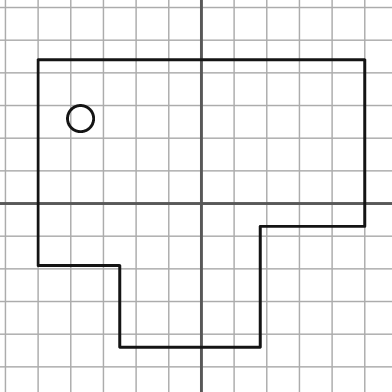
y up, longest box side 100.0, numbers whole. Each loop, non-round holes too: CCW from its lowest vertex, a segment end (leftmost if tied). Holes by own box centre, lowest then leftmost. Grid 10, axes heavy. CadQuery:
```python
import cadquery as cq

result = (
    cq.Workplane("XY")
    .moveTo(-25.0, -44.0)
    .lineTo(18.0, -44.0)
    .lineTo(18.0, -7.0)
    .lineTo(50.0, -7.0)
    .lineTo(50.0, 44.0)
    .lineTo(-50.0, 44.0)
    .lineTo(-50.0, -19.0)
    .lineTo(-25.0, -19.0)
    .close()
    .moveTo(-37.0, 26.0)
    .circle(4.0)
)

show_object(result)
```